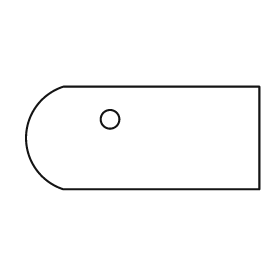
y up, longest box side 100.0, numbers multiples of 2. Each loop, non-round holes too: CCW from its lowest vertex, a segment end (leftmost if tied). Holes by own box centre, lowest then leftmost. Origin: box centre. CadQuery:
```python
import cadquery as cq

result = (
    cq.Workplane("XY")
    .moveTo(-34.0, -22.0)
    .lineTo(50.0, -22.0)
    .lineTo(50.0, 22.0)
    .lineTo(-34.0, 22.0)
    .threePointArc((-50.0, 0.0), (-34.0, -22.0))
    .close()
    .moveTo(-14.0, 8.0)
    .circle(4.0)
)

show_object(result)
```